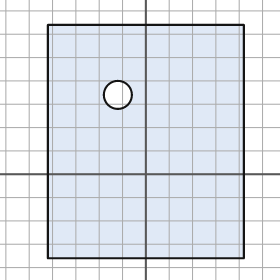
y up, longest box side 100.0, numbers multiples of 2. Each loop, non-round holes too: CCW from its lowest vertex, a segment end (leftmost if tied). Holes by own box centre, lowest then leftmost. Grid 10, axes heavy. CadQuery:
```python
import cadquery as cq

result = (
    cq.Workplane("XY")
    .moveTo(-42.0, -36.0)
    .lineTo(42.0, -36.0)
    .lineTo(42.0, 64.0)
    .lineTo(-42.0, 64.0)
    .close()
    .moveTo(-12.0, 34.0)
    .circle(6.0)
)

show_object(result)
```